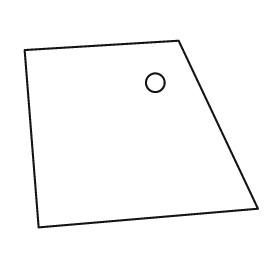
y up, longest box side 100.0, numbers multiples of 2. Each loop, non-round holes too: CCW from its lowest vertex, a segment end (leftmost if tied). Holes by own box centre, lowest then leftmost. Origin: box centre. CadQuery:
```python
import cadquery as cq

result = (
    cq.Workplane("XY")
    .moveTo(-44.0, -40.0)
    .lineTo(50.0, -32.0)
    .lineTo(16.0, 40.0)
    .lineTo(-50.0, 36.0)
    .close()
    .moveTo(6.0, 22.0)
    .circle(4.0)
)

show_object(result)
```